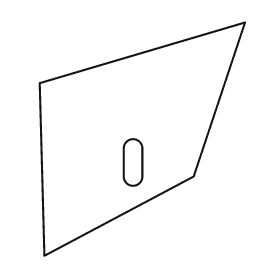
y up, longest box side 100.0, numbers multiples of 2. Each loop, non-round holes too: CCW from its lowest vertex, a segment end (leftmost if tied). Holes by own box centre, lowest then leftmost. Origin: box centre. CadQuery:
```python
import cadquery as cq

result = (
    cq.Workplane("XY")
    .moveTo(-42.0, -50.0)
    .lineTo(22.0, -16.0)
    .lineTo(44.0, 50.0)
    .lineTo(-44.0, 24.0)
    .close()
    .moveTo(-8.0, -16.0)
    .threePointArc((-4.0, -20.0), (0.0, -16.0))
    .lineTo(0.0, -4.0)
    .threePointArc((-4.0, 0.0), (-8.0, -4.0))
    .close()
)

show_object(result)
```